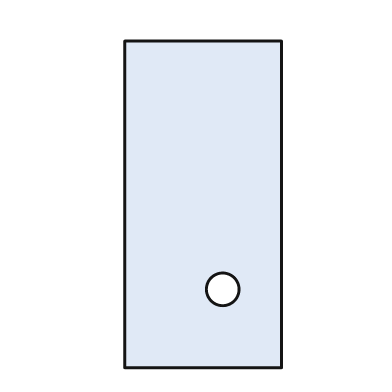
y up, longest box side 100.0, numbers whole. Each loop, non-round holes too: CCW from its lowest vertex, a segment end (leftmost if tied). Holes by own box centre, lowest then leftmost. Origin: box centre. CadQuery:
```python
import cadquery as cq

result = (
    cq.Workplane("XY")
    .moveTo(-24.0, -50.0)
    .lineTo(24.0, -50.0)
    .lineTo(24.0, 50.0)
    .lineTo(-24.0, 50.0)
    .close()
    .moveTo(6.0, -26.0)
    .circle(5.0)
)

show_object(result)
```